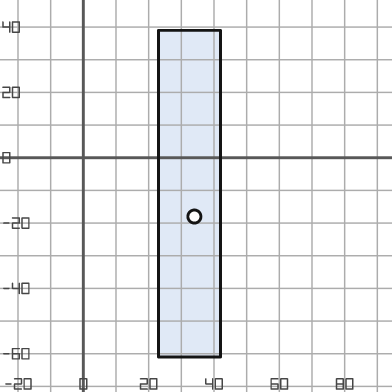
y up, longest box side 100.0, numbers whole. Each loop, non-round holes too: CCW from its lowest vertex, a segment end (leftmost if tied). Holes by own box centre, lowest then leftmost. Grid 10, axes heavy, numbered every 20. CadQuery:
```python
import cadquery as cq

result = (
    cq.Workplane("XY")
    .moveTo(23.0, -61.0)
    .lineTo(42.0, -61.0)
    .lineTo(42.0, 39.0)
    .lineTo(23.0, 39.0)
    .close()
    .moveTo(34.0, -18.0)
    .circle(2.0)
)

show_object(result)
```